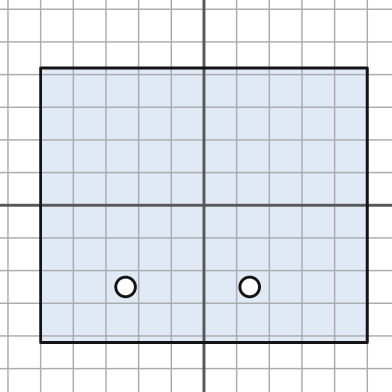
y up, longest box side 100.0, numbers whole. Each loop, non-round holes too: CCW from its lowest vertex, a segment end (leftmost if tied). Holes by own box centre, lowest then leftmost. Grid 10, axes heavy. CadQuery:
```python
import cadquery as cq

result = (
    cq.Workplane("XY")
    .moveTo(-50.0, -42.0)
    .lineTo(50.0, -42.0)
    .lineTo(50.0, 42.0)
    .lineTo(-50.0, 42.0)
    .close()
    .moveTo(-24.0, -25.0)
    .circle(3.0)
    .moveTo(14.0, -25.0)
    .circle(3.0)
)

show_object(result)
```